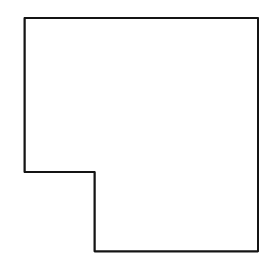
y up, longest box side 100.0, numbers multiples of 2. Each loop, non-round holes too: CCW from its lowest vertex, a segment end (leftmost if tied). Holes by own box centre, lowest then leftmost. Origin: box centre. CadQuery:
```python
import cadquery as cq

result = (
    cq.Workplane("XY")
    .moveTo(-20.0, -50.0)
    .lineTo(50.0, -50.0)
    .lineTo(50.0, 50.0)
    .lineTo(-50.0, 50.0)
    .lineTo(-50.0, -16.0)
    .lineTo(-20.0, -16.0)
    .close()
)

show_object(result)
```